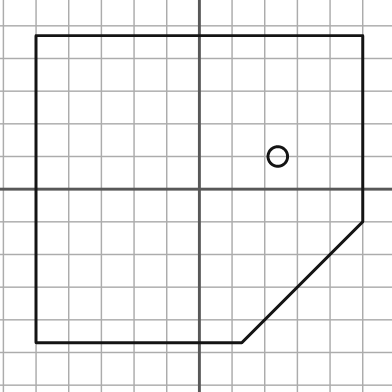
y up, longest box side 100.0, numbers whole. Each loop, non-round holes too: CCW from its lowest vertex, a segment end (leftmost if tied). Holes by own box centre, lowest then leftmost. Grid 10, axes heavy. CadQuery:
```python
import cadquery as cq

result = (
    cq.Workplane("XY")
    .moveTo(-50.0, -47.0)
    .lineTo(13.0, -47.0)
    .lineTo(50.0, -10.0)
    .lineTo(50.0, 47.0)
    .lineTo(-50.0, 47.0)
    .close()
    .moveTo(24.0, 10.0)
    .circle(3.0)
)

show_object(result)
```